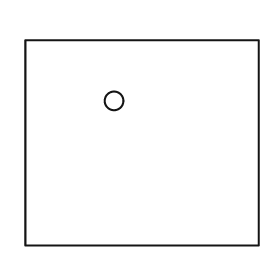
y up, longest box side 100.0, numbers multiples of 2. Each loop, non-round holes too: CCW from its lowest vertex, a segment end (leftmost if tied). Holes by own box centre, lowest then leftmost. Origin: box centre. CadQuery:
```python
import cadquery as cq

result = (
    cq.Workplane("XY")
    .moveTo(-50.0, -44.0)
    .lineTo(50.0, -44.0)
    .lineTo(50.0, 44.0)
    .lineTo(-50.0, 44.0)
    .close()
    .moveTo(-12.0, 18.0)
    .circle(4.0)
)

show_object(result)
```